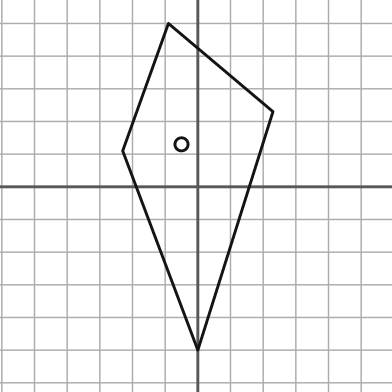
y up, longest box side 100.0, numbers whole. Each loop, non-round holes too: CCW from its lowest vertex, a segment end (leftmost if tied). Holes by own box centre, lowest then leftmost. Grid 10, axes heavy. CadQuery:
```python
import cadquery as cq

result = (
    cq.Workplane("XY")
    .moveTo(0.0, -50.0)
    .lineTo(23.0, 23.0)
    .lineTo(-9.0, 50.0)
    .lineTo(-23.0, 11.0)
    .close()
    .moveTo(-5.0, 13.0)
    .circle(2.0)
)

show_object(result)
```